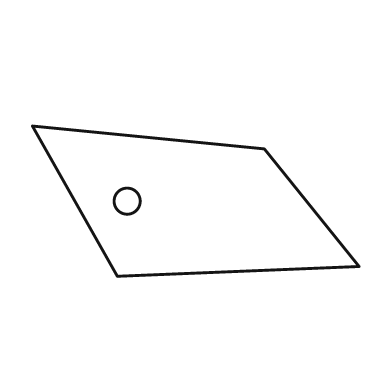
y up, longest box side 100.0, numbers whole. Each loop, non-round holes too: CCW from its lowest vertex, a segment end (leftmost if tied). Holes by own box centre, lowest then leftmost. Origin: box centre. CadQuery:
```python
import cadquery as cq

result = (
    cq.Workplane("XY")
    .moveTo(-24.0, -23.0)
    .lineTo(50.0, -20.0)
    .lineTo(21.0, 16.0)
    .lineTo(-50.0, 23.0)
    .close()
    .moveTo(-21.0, 0.0)
    .circle(4.0)
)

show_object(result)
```